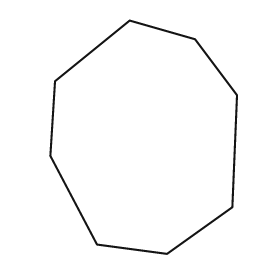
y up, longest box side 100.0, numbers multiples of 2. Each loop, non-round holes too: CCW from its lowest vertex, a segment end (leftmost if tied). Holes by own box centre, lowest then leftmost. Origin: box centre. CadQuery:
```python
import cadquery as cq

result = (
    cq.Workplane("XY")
    .moveTo(10.0, -50.0)
    .lineTo(38.0, -30.0)
    .lineTo(40.0, 18.0)
    .lineTo(22.0, 42.0)
    .lineTo(-6.0, 50.0)
    .lineTo(-38.0, 24.0)
    .lineTo(-40.0, -8.0)
    .lineTo(-20.0, -46.0)
    .close()
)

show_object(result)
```